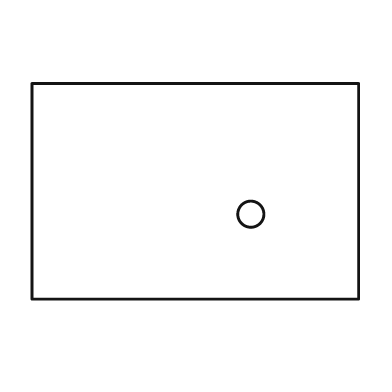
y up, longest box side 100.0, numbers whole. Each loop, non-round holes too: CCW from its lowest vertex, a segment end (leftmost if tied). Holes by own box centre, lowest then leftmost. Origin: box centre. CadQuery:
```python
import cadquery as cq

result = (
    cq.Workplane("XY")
    .moveTo(-50.0, -33.0)
    .lineTo(50.0, -33.0)
    .lineTo(50.0, 33.0)
    .lineTo(-50.0, 33.0)
    .close()
    .moveTo(17.0, -7.0)
    .circle(4.0)
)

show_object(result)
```